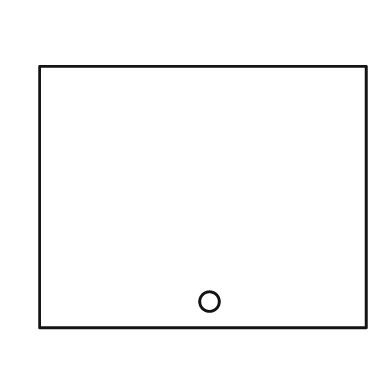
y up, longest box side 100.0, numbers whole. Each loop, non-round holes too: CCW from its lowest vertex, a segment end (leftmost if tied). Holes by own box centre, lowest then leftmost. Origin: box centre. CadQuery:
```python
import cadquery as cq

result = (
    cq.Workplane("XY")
    .moveTo(-50.0, -40.0)
    .lineTo(50.0, -40.0)
    .lineTo(50.0, 40.0)
    .lineTo(-50.0, 40.0)
    .close()
    .moveTo(2.0, -32.0)
    .circle(3.0)
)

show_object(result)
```